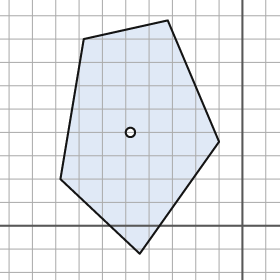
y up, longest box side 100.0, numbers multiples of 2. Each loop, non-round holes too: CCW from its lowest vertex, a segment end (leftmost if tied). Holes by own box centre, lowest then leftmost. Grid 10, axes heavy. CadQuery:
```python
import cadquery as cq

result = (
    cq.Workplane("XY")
    .moveTo(-44.0, -12.0)
    .lineTo(-10.0, 36.0)
    .lineTo(-32.0, 88.0)
    .lineTo(-68.0, 80.0)
    .lineTo(-78.0, 20.0)
    .close()
    .moveTo(-48.0, 40.0)
    .circle(2.0)
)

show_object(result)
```